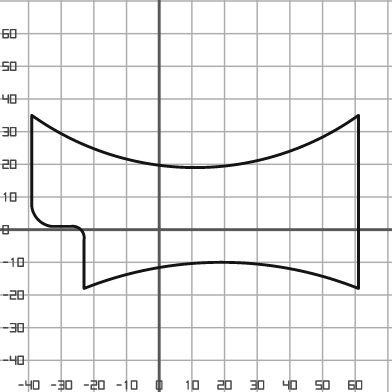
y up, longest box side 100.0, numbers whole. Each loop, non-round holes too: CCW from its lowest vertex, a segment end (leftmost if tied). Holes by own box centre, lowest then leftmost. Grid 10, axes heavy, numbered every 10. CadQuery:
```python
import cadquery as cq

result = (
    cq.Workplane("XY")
    .moveTo(-23.0, -18.0)
    .threePointArc((19.0, -10.0), (61.0, -18.0))
    .lineTo(61.0, 35.0)
    .threePointArc((11.0, 19.0), (-39.0, 35.0))
    .lineTo(-39.0, 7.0)
    .threePointArc((-37.0, 3.0), (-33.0, 1.0))
    .lineTo(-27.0, 1.0)
    .threePointArc((-24.0, 0.0), (-23.0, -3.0))
    .close()
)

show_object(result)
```